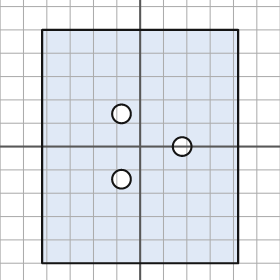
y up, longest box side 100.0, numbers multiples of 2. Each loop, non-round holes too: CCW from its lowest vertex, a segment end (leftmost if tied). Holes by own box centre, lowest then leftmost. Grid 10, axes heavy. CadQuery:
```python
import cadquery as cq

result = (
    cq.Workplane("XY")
    .moveTo(-42.0, -50.0)
    .lineTo(42.0, -50.0)
    .lineTo(42.0, 50.0)
    .lineTo(-42.0, 50.0)
    .close()
    .moveTo(-8.0, -14.0)
    .circle(4.0)
    .moveTo(18.0, 0.0)
    .circle(4.0)
    .moveTo(-8.0, 14.0)
    .circle(4.0)
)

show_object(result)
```